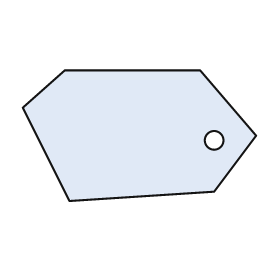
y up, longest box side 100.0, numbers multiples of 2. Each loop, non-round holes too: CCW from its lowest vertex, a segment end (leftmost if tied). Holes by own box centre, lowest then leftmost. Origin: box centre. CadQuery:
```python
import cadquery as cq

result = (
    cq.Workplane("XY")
    .moveTo(-30.0, -28.0)
    .lineTo(32.0, -24.0)
    .lineTo(50.0, 0.0)
    .lineTo(26.0, 28.0)
    .lineTo(-32.0, 28.0)
    .lineTo(-50.0, 12.0)
    .close()
    .moveTo(32.0, -2.0)
    .circle(4.0)
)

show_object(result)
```